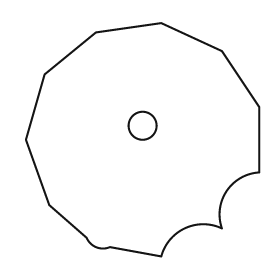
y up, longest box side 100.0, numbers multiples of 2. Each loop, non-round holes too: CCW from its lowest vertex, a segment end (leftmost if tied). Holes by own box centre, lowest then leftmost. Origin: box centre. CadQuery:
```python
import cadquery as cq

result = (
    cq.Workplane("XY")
    .moveTo(8.0, -50.0)
    .threePointArc((18.0, -38.0), (34.0, -38.0))
    .threePointArc((36.0, -22.0), (50.0, -14.0))
    .lineTo(50.0, 14.0)
    .lineTo(34.0, 38.0)
    .lineTo(8.0, 50.0)
    .lineTo(-20.0, 46.0)
    .lineTo(-42.0, 28.0)
    .lineTo(-50.0, 0.0)
    .lineTo(-40.0, -28.0)
    .lineTo(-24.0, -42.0)
    .threePointArc((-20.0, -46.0), (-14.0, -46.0))
    .close()
    .moveTo(0.0, 6.0)
    .circle(6.0)
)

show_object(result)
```